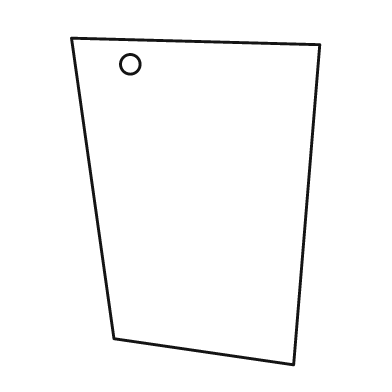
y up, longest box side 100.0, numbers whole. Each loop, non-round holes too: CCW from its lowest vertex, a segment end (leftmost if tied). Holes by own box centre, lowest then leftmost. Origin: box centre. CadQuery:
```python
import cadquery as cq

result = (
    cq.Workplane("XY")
    .moveTo(30.0, -50.0)
    .lineTo(38.0, 48.0)
    .lineTo(-38.0, 50.0)
    .lineTo(-25.0, -42.0)
    .close()
    .moveTo(-20.0, 42.0)
    .circle(3.0)
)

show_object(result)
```